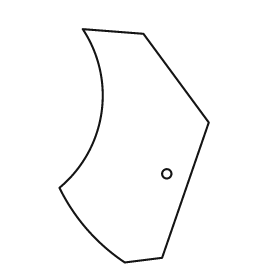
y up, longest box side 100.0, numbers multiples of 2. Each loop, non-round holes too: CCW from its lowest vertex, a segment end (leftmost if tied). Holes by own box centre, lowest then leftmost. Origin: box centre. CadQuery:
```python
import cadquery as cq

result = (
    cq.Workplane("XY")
    .moveTo(-4.0, -50.0)
    .lineTo(12.0, -48.0)
    .lineTo(32.0, 10.0)
    .lineTo(4.0, 48.0)
    .lineTo(-22.0, 50.0)
    .threePointArc((-14.0, 14.0), (-32.0, -18.0))
    .threePointArc((-20.0, -36.0), (-4.0, -50.0))
    .close()
    .moveTo(14.0, -12.0)
    .circle(2.0)
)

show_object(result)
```